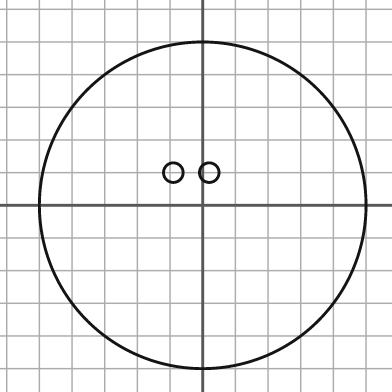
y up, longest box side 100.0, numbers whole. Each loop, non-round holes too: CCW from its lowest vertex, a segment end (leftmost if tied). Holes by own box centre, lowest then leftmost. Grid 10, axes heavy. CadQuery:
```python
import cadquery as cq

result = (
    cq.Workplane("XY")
    .moveTo(0.0, 0.0)
    .circle(50.0)
    .moveTo(-9.0, 10.0)
    .circle(3.0)
    .moveTo(2.0, 10.0)
    .circle(3.0)
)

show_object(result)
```